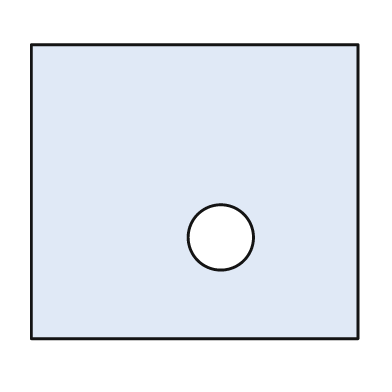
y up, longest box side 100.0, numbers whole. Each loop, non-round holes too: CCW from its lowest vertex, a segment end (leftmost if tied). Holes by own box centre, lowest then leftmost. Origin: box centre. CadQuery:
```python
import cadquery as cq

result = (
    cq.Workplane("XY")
    .moveTo(-50.0, -45.0)
    .lineTo(50.0, -45.0)
    .lineTo(50.0, 45.0)
    .lineTo(-50.0, 45.0)
    .close()
    .moveTo(8.0, -14.0)
    .circle(10.0)
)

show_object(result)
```